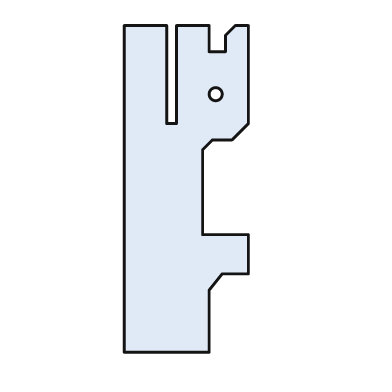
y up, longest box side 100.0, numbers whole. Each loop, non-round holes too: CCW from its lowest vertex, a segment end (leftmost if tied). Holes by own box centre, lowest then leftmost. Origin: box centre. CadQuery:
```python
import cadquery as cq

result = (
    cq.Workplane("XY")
    .moveTo(-19.0, -50.0)
    .lineTo(7.0, -50.0)
    .lineTo(7.0, -31.0)
    .lineTo(11.0, -26.0)
    .lineTo(19.0, -26.0)
    .lineTo(19.0, -14.0)
    .lineTo(5.0, -14.0)
    .lineTo(5.0, 12.0)
    .lineTo(8.0, 15.0)
    .lineTo(14.0, 15.0)
    .lineTo(19.0, 20.0)
    .lineTo(19.0, 50.0)
    .lineTo(15.0, 50.0)
    .lineTo(12.0, 47.0)
    .lineTo(12.0, 42.0)
    .lineTo(7.0, 42.0)
    .lineTo(7.0, 50.0)
    .lineTo(-3.0, 50.0)
    .lineTo(-3.0, 20.0)
    .lineTo(-6.0, 20.0)
    .lineTo(-6.0, 50.0)
    .lineTo(-19.0, 50.0)
    .close()
    .moveTo(9.0, 29.0)
    .circle(2.0)
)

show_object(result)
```